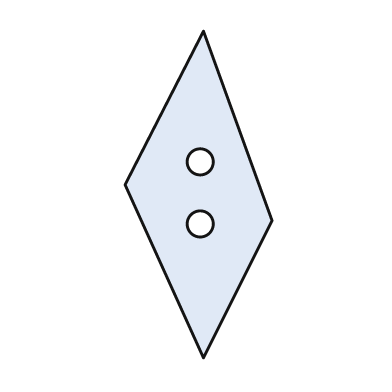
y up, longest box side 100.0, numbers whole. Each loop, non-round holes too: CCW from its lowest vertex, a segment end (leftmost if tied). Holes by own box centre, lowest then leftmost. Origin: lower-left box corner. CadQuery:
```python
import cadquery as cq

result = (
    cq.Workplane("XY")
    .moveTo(24.0, 0.0)
    .lineTo(45.0, 42.0)
    .lineTo(24.0, 100.0)
    .lineTo(0.0, 53.0)
    .close()
    .moveTo(23.0, 41.0)
    .circle(4.0)
    .moveTo(23.0, 60.0)
    .circle(4.0)
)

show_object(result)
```